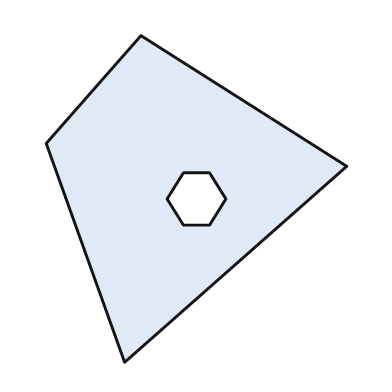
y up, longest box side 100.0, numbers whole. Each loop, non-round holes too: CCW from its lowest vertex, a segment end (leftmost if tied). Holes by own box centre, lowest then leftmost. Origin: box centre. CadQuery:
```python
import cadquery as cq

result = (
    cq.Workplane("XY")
    .moveTo(-22.0, -50.0)
    .lineTo(46.0, 10.0)
    .lineTo(-17.0, 50.0)
    .lineTo(-46.0, 17.0)
    .close()
    .moveTo(-4.0, -8.0)
    .lineTo(4.0, -8.0)
    .lineTo(9.0, 0.0)
    .lineTo(4.0, 8.0)
    .lineTo(-4.0, 8.0)
    .lineTo(-9.0, 0.0)
    .close()
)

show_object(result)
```